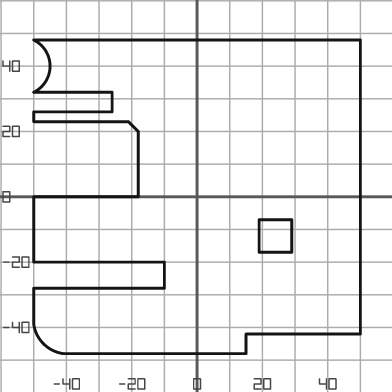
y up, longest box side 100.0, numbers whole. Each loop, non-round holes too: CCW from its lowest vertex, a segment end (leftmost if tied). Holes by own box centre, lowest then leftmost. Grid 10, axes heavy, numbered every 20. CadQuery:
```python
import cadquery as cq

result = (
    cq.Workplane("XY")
    .moveTo(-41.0, -48.0)
    .lineTo(15.0, -48.0)
    .lineTo(15.0, -42.0)
    .lineTo(50.0, -42.0)
    .lineTo(50.0, 48.0)
    .lineTo(-50.0, 48.0)
    .threePointArc((-45.0, 40.0), (-50.0, 32.0))
    .lineTo(-26.0, 32.0)
    .lineTo(-26.0, 26.0)
    .lineTo(-50.0, 26.0)
    .lineTo(-50.0, 23.0)
    .lineTo(-21.0, 23.0)
    .lineTo(-18.0, 20.0)
    .lineTo(-18.0, 0.0)
    .lineTo(-50.0, 0.0)
    .lineTo(-50.0, -20.0)
    .lineTo(-10.0, -20.0)
    .lineTo(-10.0, -28.0)
    .lineTo(-50.0, -28.0)
    .lineTo(-50.0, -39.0)
    .threePointArc((-47.0, -45.0), (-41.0, -48.0))
    .close()
    .moveTo(19.0, -17.0)
    .lineTo(29.0, -17.0)
    .lineTo(29.0, -7.0)
    .lineTo(19.0, -7.0)
    .close()
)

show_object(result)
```